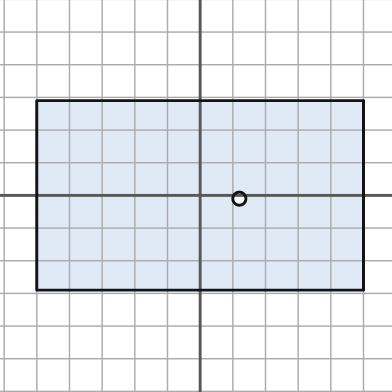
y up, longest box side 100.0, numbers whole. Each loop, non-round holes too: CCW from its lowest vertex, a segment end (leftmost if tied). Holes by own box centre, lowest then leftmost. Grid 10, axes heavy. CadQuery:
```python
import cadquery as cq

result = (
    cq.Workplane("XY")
    .moveTo(-50.0, -29.0)
    .lineTo(50.0, -29.0)
    .lineTo(50.0, 29.0)
    .lineTo(-50.0, 29.0)
    .close()
    .moveTo(12.0, -1.0)
    .circle(2.0)
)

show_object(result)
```